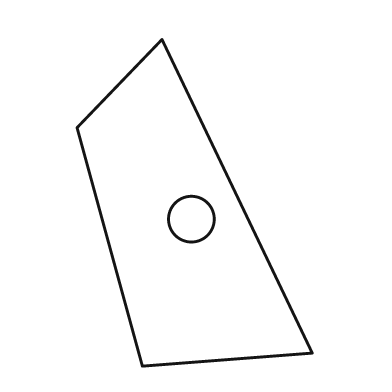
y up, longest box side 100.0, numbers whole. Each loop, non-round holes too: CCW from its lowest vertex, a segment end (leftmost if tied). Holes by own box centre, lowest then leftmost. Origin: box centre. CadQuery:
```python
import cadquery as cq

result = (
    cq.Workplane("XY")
    .moveTo(-16.0, -50.0)
    .lineTo(36.0, -46.0)
    .lineTo(-10.0, 50.0)
    .lineTo(-36.0, 23.0)
    .close()
    .moveTo(-1.0, -5.0)
    .circle(7.0)
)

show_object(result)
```